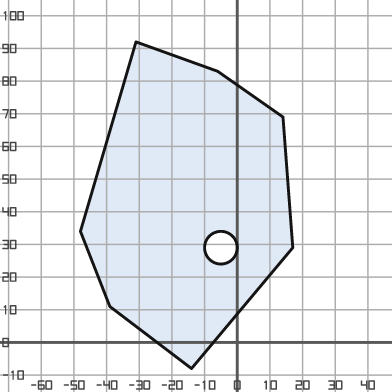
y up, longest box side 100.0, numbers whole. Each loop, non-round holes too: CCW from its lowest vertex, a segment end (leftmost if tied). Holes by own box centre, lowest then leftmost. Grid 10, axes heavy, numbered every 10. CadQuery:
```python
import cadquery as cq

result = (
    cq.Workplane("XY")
    .moveTo(-14.0, -8.0)
    .lineTo(17.0, 29.0)
    .lineTo(14.0, 69.0)
    .lineTo(-6.0, 83.0)
    .lineTo(-31.0, 92.0)
    .lineTo(-48.0, 34.0)
    .lineTo(-39.0, 11.0)
    .close()
    .moveTo(-5.0, 29.0)
    .circle(5.0)
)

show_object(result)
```